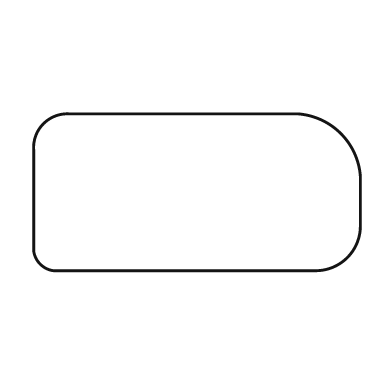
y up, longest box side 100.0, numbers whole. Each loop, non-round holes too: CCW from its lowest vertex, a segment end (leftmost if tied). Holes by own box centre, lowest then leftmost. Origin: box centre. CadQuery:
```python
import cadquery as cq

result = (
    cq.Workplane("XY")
    .moveTo(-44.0, -24.0)
    .lineTo(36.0, -24.0)
    .threePointArc((46.0, -20.0), (50.0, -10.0))
    .lineTo(50.0, 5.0)
    .threePointArc((44.0, 18.0), (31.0, 24.0))
    .lineTo(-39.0, 24.0)
    .threePointArc((-47.0, 21.0), (-50.0, 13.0))
    .lineTo(-50.0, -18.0)
    .threePointArc((-48.0, -22.0), (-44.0, -24.0))
    .close()
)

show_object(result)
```